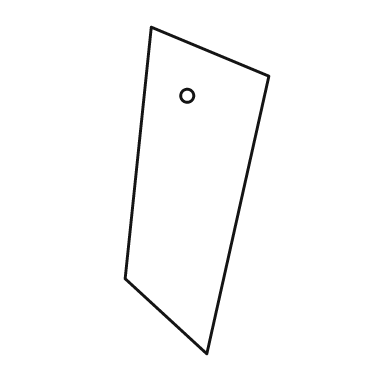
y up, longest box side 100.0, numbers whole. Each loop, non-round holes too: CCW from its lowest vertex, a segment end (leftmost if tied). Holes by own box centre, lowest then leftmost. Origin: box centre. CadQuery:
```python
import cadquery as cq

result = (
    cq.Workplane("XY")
    .moveTo(3.0, -50.0)
    .lineTo(22.0, 35.0)
    .lineTo(-14.0, 50.0)
    .lineTo(-22.0, -27.0)
    .close()
    .moveTo(-3.0, 29.0)
    .circle(2.0)
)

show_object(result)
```